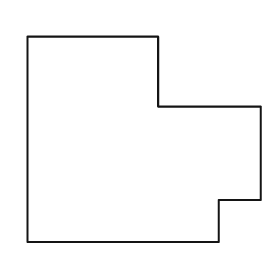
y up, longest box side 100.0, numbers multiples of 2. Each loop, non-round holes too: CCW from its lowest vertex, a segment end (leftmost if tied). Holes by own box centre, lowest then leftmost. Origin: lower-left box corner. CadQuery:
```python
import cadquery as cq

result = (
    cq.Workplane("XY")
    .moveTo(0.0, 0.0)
    .lineTo(82.0, 0.0)
    .lineTo(82.0, 18.0)
    .lineTo(100.0, 18.0)
    .lineTo(100.0, 58.0)
    .lineTo(56.0, 58.0)
    .lineTo(56.0, 88.0)
    .lineTo(0.0, 88.0)
    .close()
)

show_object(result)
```